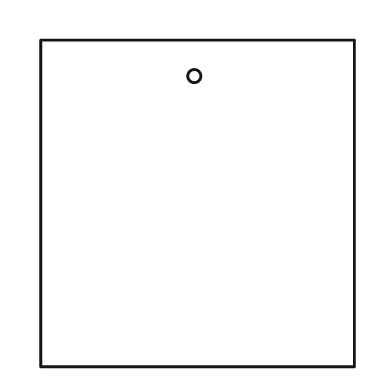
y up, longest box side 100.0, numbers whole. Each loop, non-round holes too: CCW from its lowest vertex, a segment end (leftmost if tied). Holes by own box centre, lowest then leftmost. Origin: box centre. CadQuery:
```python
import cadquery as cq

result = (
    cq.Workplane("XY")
    .moveTo(-48.0, -50.0)
    .lineTo(48.0, -50.0)
    .lineTo(48.0, 50.0)
    .lineTo(-48.0, 50.0)
    .close()
    .moveTo(-1.0, 39.0)
    .circle(2.0)
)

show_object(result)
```